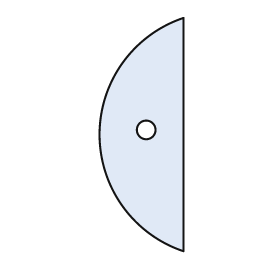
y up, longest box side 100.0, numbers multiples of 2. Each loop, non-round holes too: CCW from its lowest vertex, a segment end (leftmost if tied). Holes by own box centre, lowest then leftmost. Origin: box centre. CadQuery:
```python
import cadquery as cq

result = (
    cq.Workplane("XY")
    .moveTo(18.0, -50.0)
    .lineTo(18.0, 50.0)
    .threePointArc((-18.0, 0.0), (18.0, -50.0))
    .close()
    .moveTo(2.0, 2.0)
    .circle(4.0)
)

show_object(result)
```